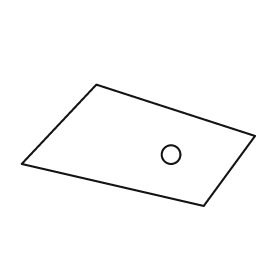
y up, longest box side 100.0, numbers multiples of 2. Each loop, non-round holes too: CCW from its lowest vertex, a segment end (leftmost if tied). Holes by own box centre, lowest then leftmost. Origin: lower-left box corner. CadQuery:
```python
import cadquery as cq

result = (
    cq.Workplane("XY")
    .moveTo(78.0, 0.0)
    .lineTo(100.0, 30.0)
    .lineTo(32.0, 52.0)
    .lineTo(0.0, 18.0)
    .close()
    .moveTo(64.0, 22.0)
    .circle(4.0)
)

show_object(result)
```